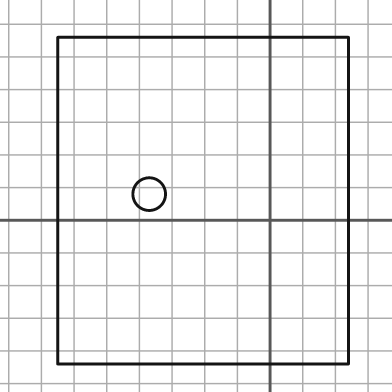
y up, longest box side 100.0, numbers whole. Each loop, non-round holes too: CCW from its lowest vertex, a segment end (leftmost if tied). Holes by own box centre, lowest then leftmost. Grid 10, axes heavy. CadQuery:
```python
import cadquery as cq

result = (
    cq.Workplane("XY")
    .moveTo(-65.0, -44.0)
    .lineTo(24.0, -44.0)
    .lineTo(24.0, 56.0)
    .lineTo(-65.0, 56.0)
    .close()
    .moveTo(-37.0, 8.0)
    .circle(5.0)
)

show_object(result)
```